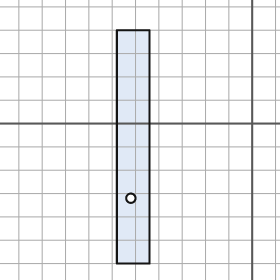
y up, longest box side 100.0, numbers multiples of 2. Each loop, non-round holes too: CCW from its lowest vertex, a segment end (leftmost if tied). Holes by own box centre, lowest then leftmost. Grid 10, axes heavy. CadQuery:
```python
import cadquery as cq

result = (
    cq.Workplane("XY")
    .moveTo(-58.0, -60.0)
    .lineTo(-44.0, -60.0)
    .lineTo(-44.0, 40.0)
    .lineTo(-58.0, 40.0)
    .close()
    .moveTo(-52.0, -32.0)
    .circle(2.0)
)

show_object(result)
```